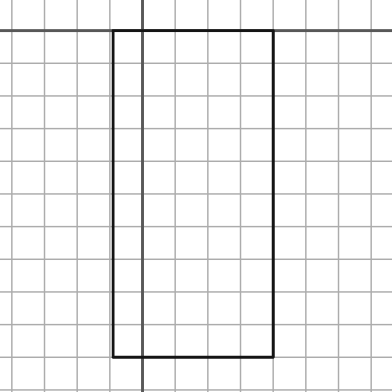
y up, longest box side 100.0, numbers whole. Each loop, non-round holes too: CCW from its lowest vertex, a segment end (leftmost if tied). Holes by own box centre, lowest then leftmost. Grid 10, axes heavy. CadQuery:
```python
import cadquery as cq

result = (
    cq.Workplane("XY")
    .moveTo(-9.0, -100.0)
    .lineTo(40.0, -100.0)
    .lineTo(40.0, 0.0)
    .lineTo(-9.0, 0.0)
    .close()
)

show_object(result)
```